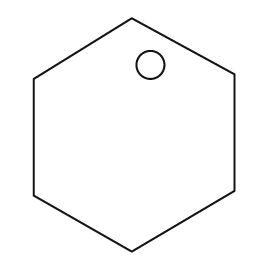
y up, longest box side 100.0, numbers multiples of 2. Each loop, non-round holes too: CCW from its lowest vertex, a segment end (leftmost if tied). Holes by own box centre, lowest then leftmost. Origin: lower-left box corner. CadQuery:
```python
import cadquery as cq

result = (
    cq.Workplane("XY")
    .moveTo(42.0, 0.0)
    .lineTo(86.0, 26.0)
    .lineTo(86.0, 76.0)
    .lineTo(42.0, 100.0)
    .lineTo(0.0, 74.0)
    .lineTo(0.0, 24.0)
    .close()
    .moveTo(50.0, 80.0)
    .circle(6.0)
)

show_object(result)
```